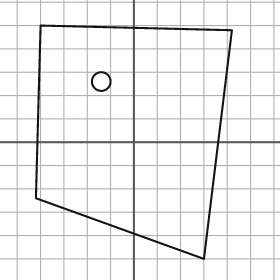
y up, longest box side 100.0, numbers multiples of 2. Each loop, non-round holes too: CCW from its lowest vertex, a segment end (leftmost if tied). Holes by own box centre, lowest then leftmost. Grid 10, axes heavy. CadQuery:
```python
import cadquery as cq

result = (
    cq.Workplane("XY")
    .moveTo(30.0, -50.0)
    .lineTo(42.0, 48.0)
    .lineTo(-40.0, 50.0)
    .lineTo(-42.0, -24.0)
    .close()
    .moveTo(-14.0, 26.0)
    .circle(4.0)
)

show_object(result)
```